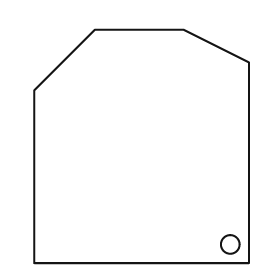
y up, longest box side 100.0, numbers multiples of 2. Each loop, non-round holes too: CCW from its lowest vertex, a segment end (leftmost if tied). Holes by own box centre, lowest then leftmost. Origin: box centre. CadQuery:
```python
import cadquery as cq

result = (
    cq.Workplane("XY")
    .moveTo(-46.0, -50.0)
    .lineTo(46.0, -50.0)
    .lineTo(46.0, 36.0)
    .lineTo(18.0, 50.0)
    .lineTo(-20.0, 50.0)
    .lineTo(-46.0, 24.0)
    .close()
    .moveTo(38.0, -42.0)
    .circle(4.0)
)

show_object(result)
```